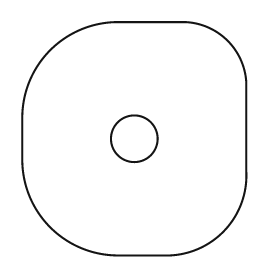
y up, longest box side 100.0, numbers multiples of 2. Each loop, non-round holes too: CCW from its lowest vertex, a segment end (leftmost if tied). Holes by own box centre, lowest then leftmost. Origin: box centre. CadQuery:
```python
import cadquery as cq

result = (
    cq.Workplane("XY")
    .moveTo(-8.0, -50.0)
    .lineTo(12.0, -50.0)
    .threePointArc((38.0, -40.0), (48.0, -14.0))
    .lineTo(48.0, 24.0)
    .threePointArc((40.0, 42.0), (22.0, 50.0))
    .lineTo(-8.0, 50.0)
    .threePointArc((-36.0, 38.0), (-48.0, 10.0))
    .lineTo(-48.0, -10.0)
    .threePointArc((-36.0, -38.0), (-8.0, -50.0))
    .close()
    .moveTo(0.0, 0.0)
    .circle(10.0)
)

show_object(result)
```